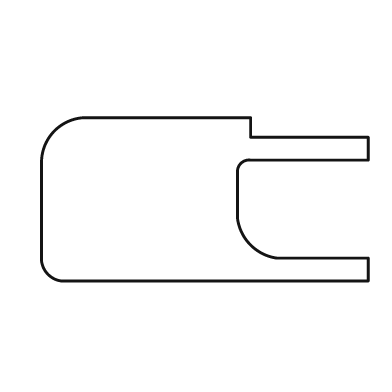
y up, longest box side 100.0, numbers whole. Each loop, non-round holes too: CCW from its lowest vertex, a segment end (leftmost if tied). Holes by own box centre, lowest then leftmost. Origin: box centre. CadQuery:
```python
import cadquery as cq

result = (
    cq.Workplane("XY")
    .moveTo(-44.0, -25.0)
    .lineTo(50.0, -25.0)
    .lineTo(50.0, -18.0)
    .lineTo(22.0, -18.0)
    .threePointArc((14.0, -14.0), (10.0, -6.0))
    .lineTo(10.0, 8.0)
    .threePointArc((11.0, 11.0), (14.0, 12.0))
    .lineTo(50.0, 12.0)
    .lineTo(50.0, 19.0)
    .lineTo(14.0, 19.0)
    .lineTo(14.0, 25.0)
    .lineTo(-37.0, 25.0)
    .threePointArc((-46.0, 21.0), (-50.0, 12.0))
    .lineTo(-50.0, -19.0)
    .threePointArc((-48.0, -23.0), (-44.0, -25.0))
    .close()
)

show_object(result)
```